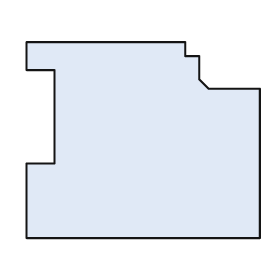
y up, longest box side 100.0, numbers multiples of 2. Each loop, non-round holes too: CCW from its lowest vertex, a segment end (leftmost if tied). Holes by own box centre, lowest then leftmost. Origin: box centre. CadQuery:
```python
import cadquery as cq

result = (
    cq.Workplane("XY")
    .moveTo(-50.0, -42.0)
    .lineTo(50.0, -42.0)
    .lineTo(50.0, 22.0)
    .lineTo(28.0, 22.0)
    .lineTo(24.0, 26.0)
    .lineTo(24.0, 36.0)
    .lineTo(18.0, 36.0)
    .lineTo(18.0, 42.0)
    .lineTo(-50.0, 42.0)
    .lineTo(-50.0, 30.0)
    .lineTo(-38.0, 30.0)
    .lineTo(-38.0, -10.0)
    .lineTo(-50.0, -10.0)
    .close()
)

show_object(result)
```